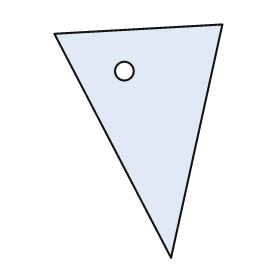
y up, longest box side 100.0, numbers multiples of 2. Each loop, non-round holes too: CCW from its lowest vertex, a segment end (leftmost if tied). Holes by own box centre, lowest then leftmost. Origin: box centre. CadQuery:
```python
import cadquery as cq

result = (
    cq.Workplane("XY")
    .moveTo(14.0, -50.0)
    .lineTo(36.0, 50.0)
    .lineTo(-36.0, 46.0)
    .close()
    .moveTo(-6.0, 30.0)
    .circle(4.0)
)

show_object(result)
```